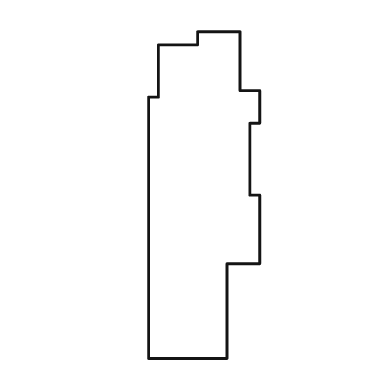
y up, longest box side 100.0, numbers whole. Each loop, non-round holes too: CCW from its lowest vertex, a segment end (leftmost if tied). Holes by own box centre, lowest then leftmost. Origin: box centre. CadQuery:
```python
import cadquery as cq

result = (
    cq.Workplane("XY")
    .moveTo(-17.0, -50.0)
    .lineTo(7.0, -50.0)
    .lineTo(7.0, -21.0)
    .lineTo(17.0, -21.0)
    .lineTo(17.0, 0.0)
    .lineTo(14.0, 0.0)
    .lineTo(14.0, 22.0)
    .lineTo(17.0, 22.0)
    .lineTo(17.0, 32.0)
    .lineTo(11.0, 32.0)
    .lineTo(11.0, 50.0)
    .lineTo(-2.0, 50.0)
    .lineTo(-2.0, 46.0)
    .lineTo(-14.0, 46.0)
    .lineTo(-14.0, 30.0)
    .lineTo(-17.0, 30.0)
    .close()
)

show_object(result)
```